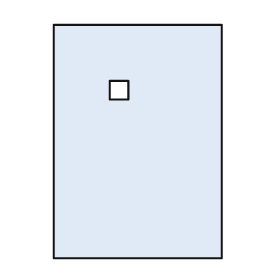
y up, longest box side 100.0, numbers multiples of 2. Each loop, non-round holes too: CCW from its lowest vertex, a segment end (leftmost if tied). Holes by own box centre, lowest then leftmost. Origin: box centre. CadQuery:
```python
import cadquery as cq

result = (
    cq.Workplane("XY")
    .moveTo(-36.0, -50.0)
    .lineTo(36.0, -50.0)
    .lineTo(36.0, 50.0)
    .lineTo(-36.0, 50.0)
    .close()
    .moveTo(-12.0, 18.0)
    .lineTo(-4.0, 18.0)
    .lineTo(-4.0, 26.0)
    .lineTo(-12.0, 26.0)
    .close()
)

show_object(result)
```